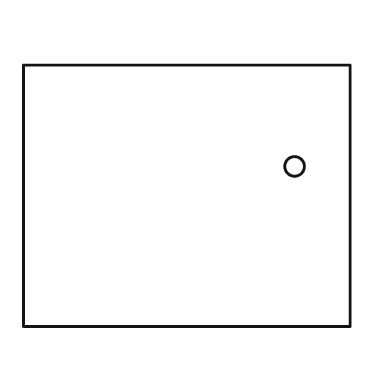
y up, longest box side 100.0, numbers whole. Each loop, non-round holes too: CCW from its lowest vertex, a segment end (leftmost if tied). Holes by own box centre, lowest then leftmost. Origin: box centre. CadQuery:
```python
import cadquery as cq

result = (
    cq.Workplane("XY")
    .moveTo(-50.0, -40.0)
    .lineTo(50.0, -40.0)
    .lineTo(50.0, 40.0)
    .lineTo(-50.0, 40.0)
    .close()
    .moveTo(33.0, 9.0)
    .circle(3.0)
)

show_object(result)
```